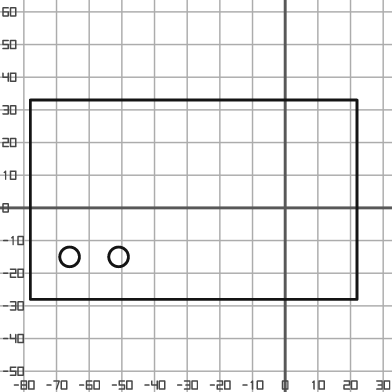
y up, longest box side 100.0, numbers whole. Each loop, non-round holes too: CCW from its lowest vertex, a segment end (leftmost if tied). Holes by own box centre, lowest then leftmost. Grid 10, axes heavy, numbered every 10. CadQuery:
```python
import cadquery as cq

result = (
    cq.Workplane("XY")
    .moveTo(-78.0, -28.0)
    .lineTo(22.0, -28.0)
    .lineTo(22.0, 33.0)
    .lineTo(-78.0, 33.0)
    .close()
    .moveTo(-66.0, -15.0)
    .circle(3.0)
    .moveTo(-51.0, -15.0)
    .circle(3.0)
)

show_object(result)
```